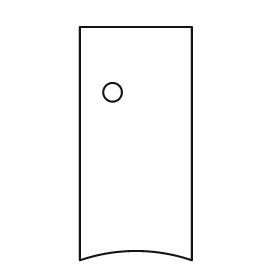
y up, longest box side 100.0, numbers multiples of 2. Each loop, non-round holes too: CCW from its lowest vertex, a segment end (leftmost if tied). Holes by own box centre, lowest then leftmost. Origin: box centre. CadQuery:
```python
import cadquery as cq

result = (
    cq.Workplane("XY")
    .moveTo(-24.0, -50.0)
    .threePointArc((0.0, -46.0), (24.0, -50.0))
    .lineTo(24.0, 50.0)
    .lineTo(-24.0, 50.0)
    .close()
    .moveTo(-10.0, 22.0)
    .circle(4.0)
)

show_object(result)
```